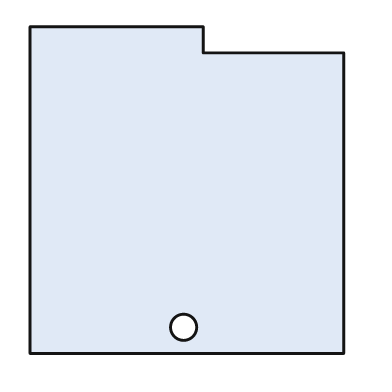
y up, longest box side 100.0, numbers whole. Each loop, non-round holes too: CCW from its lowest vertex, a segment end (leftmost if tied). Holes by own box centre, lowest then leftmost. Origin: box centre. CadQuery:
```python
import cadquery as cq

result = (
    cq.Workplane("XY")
    .moveTo(-48.0, -50.0)
    .lineTo(48.0, -50.0)
    .lineTo(48.0, 42.0)
    .lineTo(5.0, 42.0)
    .lineTo(5.0, 50.0)
    .lineTo(-48.0, 50.0)
    .close()
    .moveTo(-1.0, -42.0)
    .circle(4.0)
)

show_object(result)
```